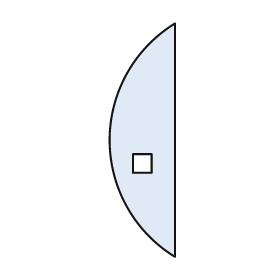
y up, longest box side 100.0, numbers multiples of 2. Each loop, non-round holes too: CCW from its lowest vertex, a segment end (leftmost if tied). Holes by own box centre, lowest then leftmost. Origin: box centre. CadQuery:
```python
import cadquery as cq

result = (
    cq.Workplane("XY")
    .moveTo(14.0, -50.0)
    .lineTo(14.0, 50.0)
    .threePointArc((-14.0, 0.0), (14.0, -50.0))
    .close()
    .moveTo(-4.0, -14.0)
    .lineTo(4.0, -14.0)
    .lineTo(4.0, -6.0)
    .lineTo(-4.0, -6.0)
    .close()
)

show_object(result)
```